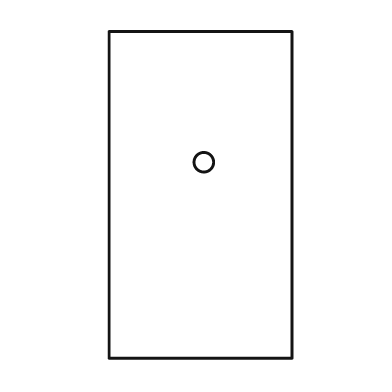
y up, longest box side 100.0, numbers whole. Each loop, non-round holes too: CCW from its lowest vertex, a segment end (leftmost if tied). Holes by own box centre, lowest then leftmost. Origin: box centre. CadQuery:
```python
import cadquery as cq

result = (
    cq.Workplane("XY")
    .moveTo(-28.0, -50.0)
    .lineTo(28.0, -50.0)
    .lineTo(28.0, 50.0)
    .lineTo(-28.0, 50.0)
    .close()
    .moveTo(1.0, 10.0)
    .circle(3.0)
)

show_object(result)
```